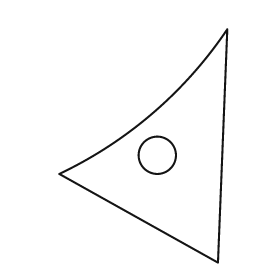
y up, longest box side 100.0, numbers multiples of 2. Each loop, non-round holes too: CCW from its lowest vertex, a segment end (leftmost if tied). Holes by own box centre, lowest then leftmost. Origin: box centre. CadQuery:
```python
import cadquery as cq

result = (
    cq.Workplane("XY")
    .moveTo(32.0, -50.0)
    .lineTo(36.0, 50.0)
    .threePointArc((4.0, 14.0), (-36.0, -12.0))
    .close()
    .moveTo(6.0, -4.0)
    .circle(8.0)
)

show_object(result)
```